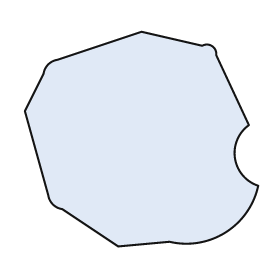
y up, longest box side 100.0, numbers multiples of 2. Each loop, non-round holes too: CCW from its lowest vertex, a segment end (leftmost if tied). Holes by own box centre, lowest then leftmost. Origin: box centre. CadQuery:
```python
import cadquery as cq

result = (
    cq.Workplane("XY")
    .moveTo(-10.0, -46.0)
    .lineTo(12.0, -44.0)
    .threePointArc((36.0, -40.0), (50.0, -20.0))
    .threePointArc((40.0, -8.0), (46.0, 6.0))
    .lineTo(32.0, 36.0)
    .threePointArc((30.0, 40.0), (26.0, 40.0))
    .lineTo(0.0, 46.0)
    .lineTo(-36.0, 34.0)
    .threePointArc((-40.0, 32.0), (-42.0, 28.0))
    .lineTo(-50.0, 12.0)
    .lineTo(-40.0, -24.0)
    .threePointArc((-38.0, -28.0), (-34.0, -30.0))
    .close()
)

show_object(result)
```